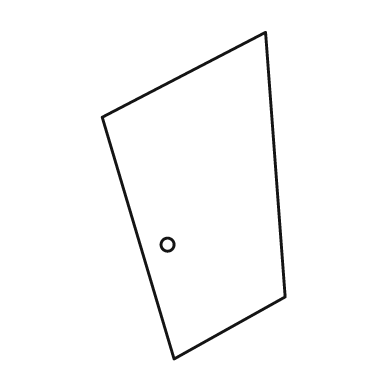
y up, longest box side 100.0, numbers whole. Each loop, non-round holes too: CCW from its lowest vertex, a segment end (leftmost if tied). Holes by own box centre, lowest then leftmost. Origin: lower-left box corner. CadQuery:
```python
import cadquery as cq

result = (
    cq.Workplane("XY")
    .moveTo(22.0, 0.0)
    .lineTo(56.0, 19.0)
    .lineTo(50.0, 100.0)
    .lineTo(0.0, 74.0)
    .close()
    .moveTo(20.0, 35.0)
    .circle(2.0)
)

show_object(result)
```